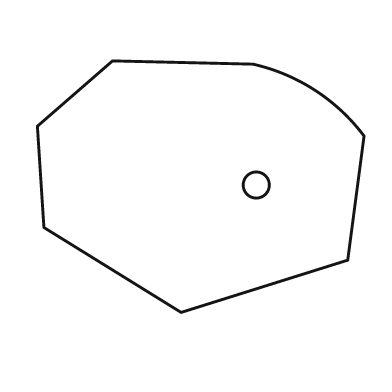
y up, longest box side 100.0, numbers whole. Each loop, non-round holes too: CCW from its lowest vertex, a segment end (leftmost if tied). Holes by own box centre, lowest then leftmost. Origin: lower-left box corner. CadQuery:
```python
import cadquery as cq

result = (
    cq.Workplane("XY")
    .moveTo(44.0, 0.0)
    .lineTo(95.0, 16.0)
    .lineTo(100.0, 54.0)
    .threePointArc((85.0, 68.0), (66.0, 76.0))
    .lineTo(23.0, 77.0)
    .lineTo(0.0, 57.0)
    .lineTo(2.0, 26.0)
    .close()
    .moveTo(67.0, 39.0)
    .circle(4.0)
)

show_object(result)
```